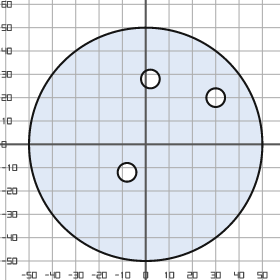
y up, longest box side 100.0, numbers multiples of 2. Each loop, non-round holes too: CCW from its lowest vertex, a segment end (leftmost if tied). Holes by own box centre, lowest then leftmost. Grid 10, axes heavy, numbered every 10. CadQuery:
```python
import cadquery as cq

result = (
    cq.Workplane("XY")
    .moveTo(0.0, 0.0)
    .circle(50.0)
    .moveTo(-8.0, -12.0)
    .circle(4.0)
    .moveTo(30.0, 20.0)
    .circle(4.0)
    .moveTo(2.0, 28.0)
    .circle(4.0)
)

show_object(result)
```